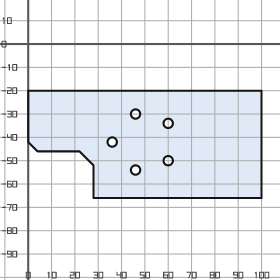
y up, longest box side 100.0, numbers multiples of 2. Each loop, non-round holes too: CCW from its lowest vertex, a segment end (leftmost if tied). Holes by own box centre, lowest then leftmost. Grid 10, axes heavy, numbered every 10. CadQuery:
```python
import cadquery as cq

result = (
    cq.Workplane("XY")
    .moveTo(28.0, -66.0)
    .lineTo(100.0, -66.0)
    .lineTo(100.0, -20.0)
    .lineTo(0.0, -20.0)
    .lineTo(0.0, -42.0)
    .lineTo(4.0, -46.0)
    .lineTo(22.0, -46.0)
    .lineTo(28.0, -52.0)
    .close()
    .moveTo(46.0, -54.0)
    .circle(2.0)
    .moveTo(60.0, -50.0)
    .circle(2.0)
    .moveTo(36.0, -42.0)
    .circle(2.0)
    .moveTo(60.0, -34.0)
    .circle(2.0)
    .moveTo(46.0, -30.0)
    .circle(2.0)
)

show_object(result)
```